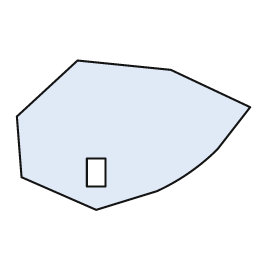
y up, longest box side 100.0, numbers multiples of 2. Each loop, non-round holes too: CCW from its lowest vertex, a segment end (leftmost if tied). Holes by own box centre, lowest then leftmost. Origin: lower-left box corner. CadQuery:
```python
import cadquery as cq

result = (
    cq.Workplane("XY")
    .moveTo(34.0, 0.0)
    .lineTo(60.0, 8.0)
    .threePointArc((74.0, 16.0), (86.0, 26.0))
    .lineTo(100.0, 44.0)
    .lineTo(66.0, 60.0)
    .lineTo(26.0, 64.0)
    .lineTo(0.0, 40.0)
    .lineTo(2.0, 14.0)
    .close()
    .moveTo(30.0, 10.0)
    .lineTo(38.0, 10.0)
    .lineTo(38.0, 22.0)
    .lineTo(30.0, 22.0)
    .close()
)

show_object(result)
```